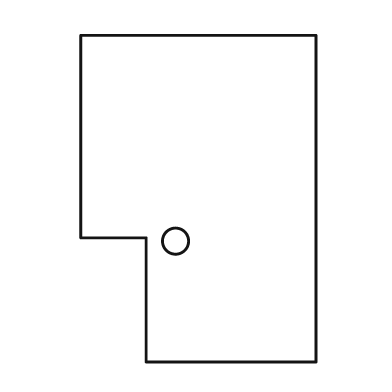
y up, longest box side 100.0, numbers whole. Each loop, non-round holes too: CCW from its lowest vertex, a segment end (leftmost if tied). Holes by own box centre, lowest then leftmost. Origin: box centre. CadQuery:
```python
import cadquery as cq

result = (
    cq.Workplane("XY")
    .moveTo(-16.0, -50.0)
    .lineTo(36.0, -50.0)
    .lineTo(36.0, 50.0)
    .lineTo(-36.0, 50.0)
    .lineTo(-36.0, -12.0)
    .lineTo(-16.0, -12.0)
    .close()
    .moveTo(-7.0, -13.0)
    .circle(4.0)
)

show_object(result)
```